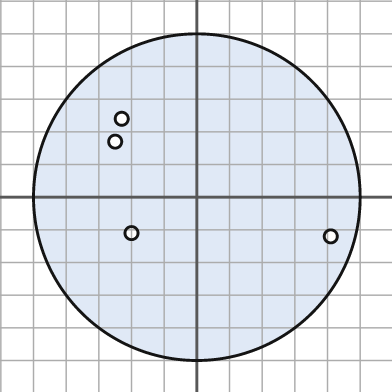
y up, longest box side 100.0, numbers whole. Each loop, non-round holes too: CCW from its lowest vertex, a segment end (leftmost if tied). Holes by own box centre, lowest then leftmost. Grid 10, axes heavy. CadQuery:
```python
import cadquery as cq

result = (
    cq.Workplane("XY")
    .moveTo(0.0, 0.0)
    .circle(50.0)
    .moveTo(41.0, -12.0)
    .circle(2.0)
    .moveTo(-20.0, -11.0)
    .circle(2.0)
    .moveTo(-25.0, 17.0)
    .circle(2.0)
    .moveTo(-23.0, 24.0)
    .circle(2.0)
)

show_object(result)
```